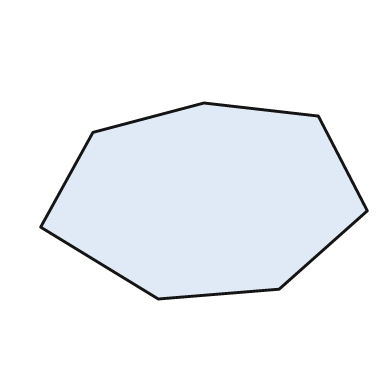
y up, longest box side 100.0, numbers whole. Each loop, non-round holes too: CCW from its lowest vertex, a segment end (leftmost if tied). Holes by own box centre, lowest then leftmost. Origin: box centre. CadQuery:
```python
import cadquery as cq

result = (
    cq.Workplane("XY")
    .moveTo(-14.0, -30.0)
    .lineTo(23.0, -27.0)
    .lineTo(50.0, -3.0)
    .lineTo(35.0, 26.0)
    .lineTo(0.0, 30.0)
    .lineTo(-34.0, 21.0)
    .lineTo(-50.0, -8.0)
    .close()
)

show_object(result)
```